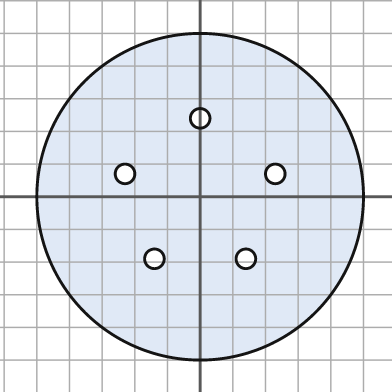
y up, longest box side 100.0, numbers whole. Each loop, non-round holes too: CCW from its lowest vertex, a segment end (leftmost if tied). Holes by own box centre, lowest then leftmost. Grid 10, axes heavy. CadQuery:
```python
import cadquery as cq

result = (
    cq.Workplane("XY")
    .moveTo(0.0, 0.0)
    .circle(50.0)
    .moveTo(-14.0, -19.0)
    .circle(3.0)
    .moveTo(14.0, -19.0)
    .circle(3.0)
    .moveTo(-23.0, 7.0)
    .circle(3.0)
    .moveTo(23.0, 7.0)
    .circle(3.0)
    .moveTo(0.0, 24.0)
    .circle(3.0)
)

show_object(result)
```